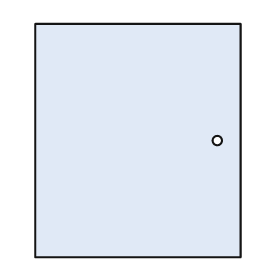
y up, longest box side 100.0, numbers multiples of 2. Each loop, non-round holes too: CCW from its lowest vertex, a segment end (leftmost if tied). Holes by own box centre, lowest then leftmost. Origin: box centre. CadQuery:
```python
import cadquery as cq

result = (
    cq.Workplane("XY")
    .moveTo(-44.0, -50.0)
    .lineTo(44.0, -50.0)
    .lineTo(44.0, 50.0)
    .lineTo(-44.0, 50.0)
    .close()
    .moveTo(34.0, 0.0)
    .circle(2.0)
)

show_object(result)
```